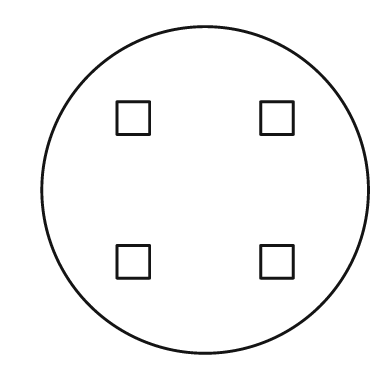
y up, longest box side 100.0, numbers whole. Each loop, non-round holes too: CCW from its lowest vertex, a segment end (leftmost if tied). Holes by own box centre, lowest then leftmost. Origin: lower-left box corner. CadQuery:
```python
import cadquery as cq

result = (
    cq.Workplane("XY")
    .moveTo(50.0, 50.0)
    .circle(50.0)
    .moveTo(23.0, 23.0)
    .lineTo(33.0, 23.0)
    .lineTo(33.0, 33.0)
    .lineTo(23.0, 33.0)
    .close()
    .moveTo(67.0, 23.0)
    .lineTo(77.0, 23.0)
    .lineTo(77.0, 33.0)
    .lineTo(67.0, 33.0)
    .close()
    .moveTo(23.0, 67.0)
    .lineTo(33.0, 67.0)
    .lineTo(33.0, 77.0)
    .lineTo(23.0, 77.0)
    .close()
    .moveTo(67.0, 67.0)
    .lineTo(77.0, 67.0)
    .lineTo(77.0, 77.0)
    .lineTo(67.0, 77.0)
    .close()
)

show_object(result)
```